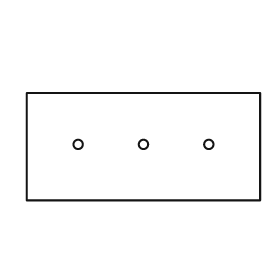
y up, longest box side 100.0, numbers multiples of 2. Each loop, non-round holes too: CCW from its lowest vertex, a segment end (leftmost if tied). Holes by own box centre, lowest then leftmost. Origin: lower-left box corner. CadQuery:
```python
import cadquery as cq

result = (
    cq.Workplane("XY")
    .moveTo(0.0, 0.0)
    .lineTo(100.0, 0.0)
    .lineTo(100.0, 46.0)
    .lineTo(0.0, 46.0)
    .close()
    .moveTo(22.0, 24.0)
    .circle(2.0)
    .moveTo(50.0, 24.0)
    .circle(2.0)
    .moveTo(78.0, 24.0)
    .circle(2.0)
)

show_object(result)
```